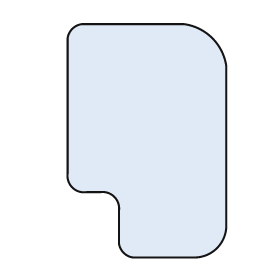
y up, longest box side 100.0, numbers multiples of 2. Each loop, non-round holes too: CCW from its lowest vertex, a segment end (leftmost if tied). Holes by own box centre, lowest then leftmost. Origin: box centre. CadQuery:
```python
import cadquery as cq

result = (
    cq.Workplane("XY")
    .moveTo(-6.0, -50.0)
    .lineTo(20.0, -50.0)
    .threePointArc((30.0, -46.0), (34.0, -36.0))
    .lineTo(34.0, 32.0)
    .threePointArc((28.0, 44.0), (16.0, 50.0))
    .lineTo(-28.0, 50.0)
    .threePointArc((-32.0, 48.0), (-34.0, 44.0))
    .lineTo(-34.0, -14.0)
    .threePointArc((-32.0, -20.0), (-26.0, -22.0))
    .lineTo(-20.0, -22.0)
    .threePointArc((-14.0, -24.0), (-12.0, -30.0))
    .lineTo(-12.0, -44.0)
    .threePointArc((-10.0, -48.0), (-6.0, -50.0))
    .close()
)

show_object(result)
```